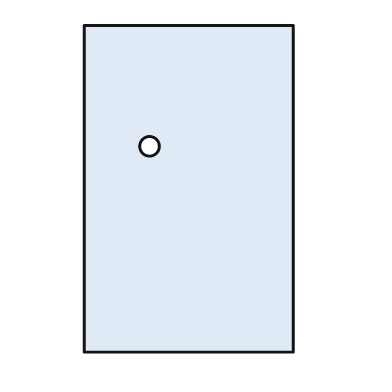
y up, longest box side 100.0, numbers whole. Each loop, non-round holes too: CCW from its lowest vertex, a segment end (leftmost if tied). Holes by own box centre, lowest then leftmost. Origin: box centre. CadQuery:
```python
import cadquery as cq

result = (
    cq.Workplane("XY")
    .moveTo(-32.0, -50.0)
    .lineTo(32.0, -50.0)
    .lineTo(32.0, 50.0)
    .lineTo(-32.0, 50.0)
    .close()
    .moveTo(-12.0, 13.0)
    .circle(3.0)
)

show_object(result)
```